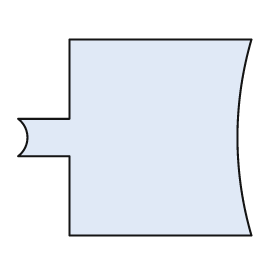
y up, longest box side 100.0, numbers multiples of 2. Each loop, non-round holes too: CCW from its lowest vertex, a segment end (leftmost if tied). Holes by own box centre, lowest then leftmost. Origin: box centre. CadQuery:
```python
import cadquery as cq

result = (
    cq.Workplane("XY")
    .moveTo(-28.0, -42.0)
    .lineTo(50.0, -42.0)
    .threePointArc((44.0, 0.0), (50.0, 42.0))
    .lineTo(-28.0, 42.0)
    .lineTo(-28.0, 8.0)
    .lineTo(-50.0, 8.0)
    .threePointArc((-46.0, 0.0), (-50.0, -8.0))
    .lineTo(-28.0, -8.0)
    .close()
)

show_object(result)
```